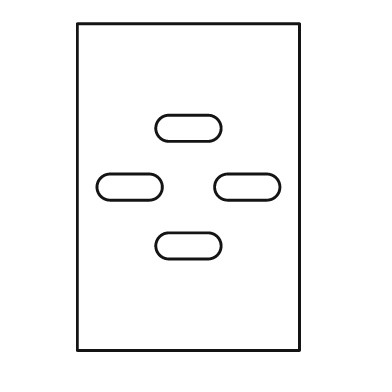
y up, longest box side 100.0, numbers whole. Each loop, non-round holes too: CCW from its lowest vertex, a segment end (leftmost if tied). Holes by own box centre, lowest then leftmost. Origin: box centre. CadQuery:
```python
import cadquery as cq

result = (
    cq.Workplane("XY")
    .moveTo(-34.0, -50.0)
    .lineTo(34.0, -50.0)
    .lineTo(34.0, 50.0)
    .lineTo(-34.0, 50.0)
    .close()
    .moveTo(-6.0, -22.0)
    .lineTo(6.0, -22.0)
    .threePointArc((10.0, -18.0), (6.0, -14.0))
    .lineTo(-6.0, -14.0)
    .threePointArc((-10.0, -18.0), (-6.0, -22.0))
    .close()
    .moveTo(-24.0, -4.0)
    .lineTo(-12.0, -4.0)
    .threePointArc((-8.0, 0.0), (-12.0, 4.0))
    .lineTo(-24.0, 4.0)
    .threePointArc((-28.0, 0.0), (-24.0, -4.0))
    .close()
    .moveTo(12.0, -4.0)
    .lineTo(24.0, -4.0)
    .threePointArc((28.0, 0.0), (24.0, 4.0))
    .lineTo(12.0, 4.0)
    .threePointArc((8.0, 0.0), (12.0, -4.0))
    .close()
    .moveTo(-6.0, 14.0)
    .lineTo(6.0, 14.0)
    .threePointArc((10.0, 18.0), (6.0, 22.0))
    .lineTo(-6.0, 22.0)
    .threePointArc((-10.0, 18.0), (-6.0, 14.0))
    .close()
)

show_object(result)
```